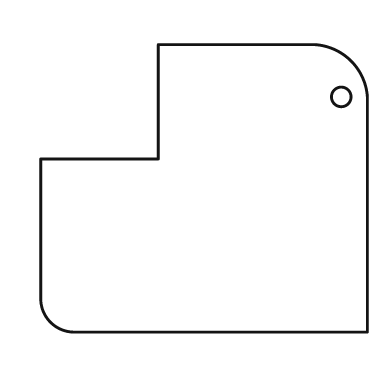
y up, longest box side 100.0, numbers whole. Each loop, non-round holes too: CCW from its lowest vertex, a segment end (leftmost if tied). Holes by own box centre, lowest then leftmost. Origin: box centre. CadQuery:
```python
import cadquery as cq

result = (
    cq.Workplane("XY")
    .moveTo(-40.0, -44.0)
    .lineTo(50.0, -44.0)
    .lineTo(50.0, 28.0)
    .threePointArc((45.0, 39.0), (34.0, 44.0))
    .lineTo(-14.0, 44.0)
    .lineTo(-14.0, 9.0)
    .lineTo(-50.0, 9.0)
    .lineTo(-50.0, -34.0)
    .threePointArc((-47.0, -41.0), (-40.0, -44.0))
    .close()
    .moveTo(42.0, 28.0)
    .circle(3.0)
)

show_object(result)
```